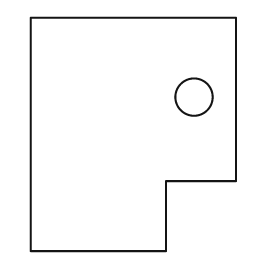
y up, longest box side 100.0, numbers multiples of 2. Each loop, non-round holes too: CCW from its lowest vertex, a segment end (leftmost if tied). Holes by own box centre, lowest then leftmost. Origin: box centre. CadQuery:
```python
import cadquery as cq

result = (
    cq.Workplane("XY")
    .moveTo(-44.0, -50.0)
    .lineTo(14.0, -50.0)
    .lineTo(14.0, -20.0)
    .lineTo(44.0, -20.0)
    .lineTo(44.0, 50.0)
    .lineTo(-44.0, 50.0)
    .close()
    .moveTo(26.0, 16.0)
    .circle(8.0)
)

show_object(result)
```